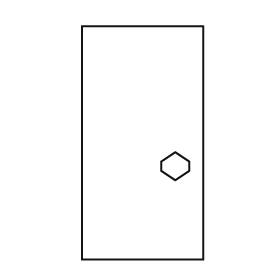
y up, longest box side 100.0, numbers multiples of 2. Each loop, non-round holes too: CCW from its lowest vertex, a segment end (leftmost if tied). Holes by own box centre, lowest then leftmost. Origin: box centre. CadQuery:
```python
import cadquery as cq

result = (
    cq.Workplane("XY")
    .moveTo(-26.0, -50.0)
    .lineTo(26.0, -50.0)
    .lineTo(26.0, 50.0)
    .lineTo(-26.0, 50.0)
    .close()
    .moveTo(14.0, -16.0)
    .lineTo(20.0, -12.0)
    .lineTo(20.0, -8.0)
    .lineTo(14.0, -4.0)
    .lineTo(8.0, -8.0)
    .lineTo(8.0, -12.0)
    .close()
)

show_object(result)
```